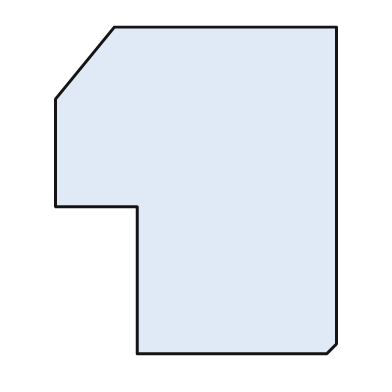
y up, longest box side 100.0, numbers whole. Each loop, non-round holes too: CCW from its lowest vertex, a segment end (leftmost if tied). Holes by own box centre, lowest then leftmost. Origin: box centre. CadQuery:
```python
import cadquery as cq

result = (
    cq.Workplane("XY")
    .moveTo(-18.0, -50.0)
    .lineTo(40.0, -50.0)
    .lineTo(43.0, -47.0)
    .lineTo(43.0, 50.0)
    .lineTo(-25.0, 50.0)
    .lineTo(-43.0, 28.0)
    .lineTo(-43.0, -5.0)
    .lineTo(-18.0, -5.0)
    .close()
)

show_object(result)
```